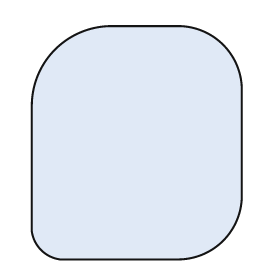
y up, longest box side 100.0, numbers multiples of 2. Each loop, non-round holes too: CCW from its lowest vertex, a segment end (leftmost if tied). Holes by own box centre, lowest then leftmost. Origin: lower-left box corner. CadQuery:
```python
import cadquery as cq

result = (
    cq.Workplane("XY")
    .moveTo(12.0, 0.0)
    .lineTo(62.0, 0.0)
    .threePointArc((82.0, 8.0), (90.0, 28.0))
    .lineTo(90.0, 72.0)
    .threePointArc((82.0, 92.0), (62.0, 100.0))
    .lineTo(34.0, 100.0)
    .threePointArc((10.0, 90.0), (0.0, 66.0))
    .lineTo(0.0, 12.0)
    .threePointArc((4.0, 4.0), (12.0, 0.0))
    .close()
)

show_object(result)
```